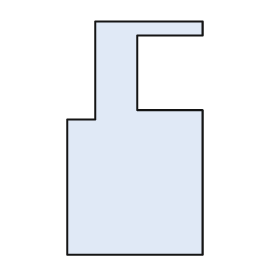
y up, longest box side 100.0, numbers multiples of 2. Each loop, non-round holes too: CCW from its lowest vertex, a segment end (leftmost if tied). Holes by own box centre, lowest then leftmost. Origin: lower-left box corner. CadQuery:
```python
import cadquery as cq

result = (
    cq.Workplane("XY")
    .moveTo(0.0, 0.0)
    .lineTo(58.0, 0.0)
    .lineTo(58.0, 62.0)
    .lineTo(30.0, 62.0)
    .lineTo(30.0, 94.0)
    .lineTo(58.0, 94.0)
    .lineTo(58.0, 100.0)
    .lineTo(12.0, 100.0)
    .lineTo(12.0, 58.0)
    .lineTo(0.0, 58.0)
    .close()
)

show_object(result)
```